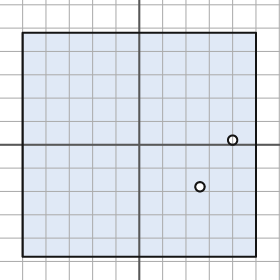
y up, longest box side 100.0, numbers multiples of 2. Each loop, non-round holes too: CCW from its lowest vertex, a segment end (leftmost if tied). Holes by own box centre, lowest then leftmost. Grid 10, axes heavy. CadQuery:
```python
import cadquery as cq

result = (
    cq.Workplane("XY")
    .moveTo(-50.0, -48.0)
    .lineTo(50.0, -48.0)
    .lineTo(50.0, 48.0)
    .lineTo(-50.0, 48.0)
    .close()
    .moveTo(26.0, -18.0)
    .circle(2.0)
    .moveTo(40.0, 2.0)
    .circle(2.0)
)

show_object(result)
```